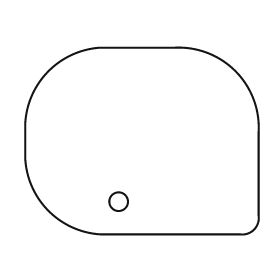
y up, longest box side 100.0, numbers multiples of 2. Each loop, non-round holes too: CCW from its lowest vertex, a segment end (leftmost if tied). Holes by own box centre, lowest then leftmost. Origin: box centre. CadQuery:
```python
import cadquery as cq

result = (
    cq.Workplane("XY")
    .moveTo(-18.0, -40.0)
    .lineTo(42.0, -40.0)
    .threePointArc((48.0, -38.0), (50.0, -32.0))
    .lineTo(50.0, 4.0)
    .threePointArc((40.0, 30.0), (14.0, 40.0))
    .lineTo(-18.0, 40.0)
    .threePointArc((-40.0, 30.0), (-50.0, 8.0))
    .lineTo(-50.0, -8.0)
    .threePointArc((-40.0, -30.0), (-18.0, -40.0))
    .close()
    .moveTo(-10.0, -26.0)
    .circle(4.0)
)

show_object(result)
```